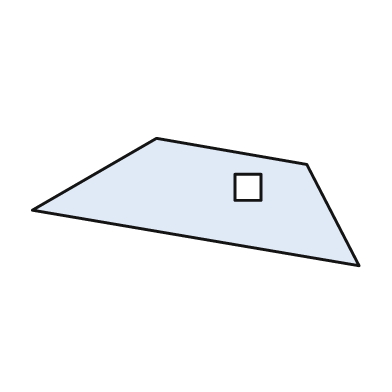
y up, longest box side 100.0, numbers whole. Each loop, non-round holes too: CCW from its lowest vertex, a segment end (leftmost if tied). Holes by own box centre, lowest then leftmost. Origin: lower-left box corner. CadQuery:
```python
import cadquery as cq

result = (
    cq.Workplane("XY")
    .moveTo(100.0, 0.0)
    .lineTo(84.0, 31.0)
    .lineTo(38.0, 39.0)
    .lineTo(0.0, 17.0)
    .close()
    .moveTo(62.0, 20.0)
    .lineTo(70.0, 20.0)
    .lineTo(70.0, 28.0)
    .lineTo(62.0, 28.0)
    .close()
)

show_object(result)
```